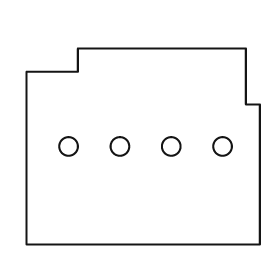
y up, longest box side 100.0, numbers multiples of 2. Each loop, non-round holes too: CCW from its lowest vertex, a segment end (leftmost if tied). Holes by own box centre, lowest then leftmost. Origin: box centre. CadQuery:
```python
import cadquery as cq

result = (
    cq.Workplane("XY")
    .moveTo(-50.0, -42.0)
    .lineTo(50.0, -42.0)
    .lineTo(50.0, 18.0)
    .lineTo(44.0, 18.0)
    .lineTo(44.0, 42.0)
    .lineTo(-28.0, 42.0)
    .lineTo(-28.0, 32.0)
    .lineTo(-50.0, 32.0)
    .close()
    .moveTo(-32.0, 0.0)
    .circle(4.0)
    .moveTo(-10.0, 0.0)
    .circle(4.0)
    .moveTo(12.0, 0.0)
    .circle(4.0)
    .moveTo(34.0, 0.0)
    .circle(4.0)
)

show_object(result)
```